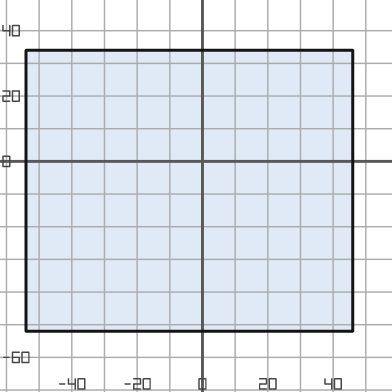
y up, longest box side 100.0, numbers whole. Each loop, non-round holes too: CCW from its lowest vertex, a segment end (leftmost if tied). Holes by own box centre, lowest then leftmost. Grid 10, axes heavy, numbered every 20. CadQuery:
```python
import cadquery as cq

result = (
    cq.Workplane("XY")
    .moveTo(-54.0, -52.0)
    .lineTo(46.0, -52.0)
    .lineTo(46.0, 34.0)
    .lineTo(-54.0, 34.0)
    .close()
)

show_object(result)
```